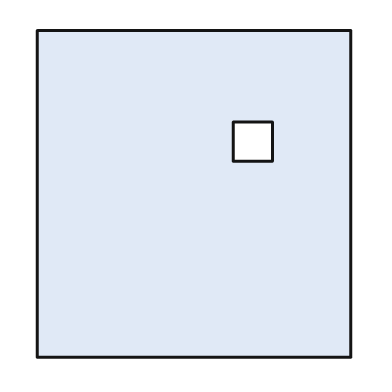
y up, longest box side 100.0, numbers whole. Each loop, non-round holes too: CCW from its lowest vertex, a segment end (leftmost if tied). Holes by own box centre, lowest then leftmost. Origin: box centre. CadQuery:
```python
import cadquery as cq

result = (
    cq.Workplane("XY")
    .moveTo(-48.0, -50.0)
    .lineTo(48.0, -50.0)
    .lineTo(48.0, 50.0)
    .lineTo(-48.0, 50.0)
    .close()
    .moveTo(12.0, 10.0)
    .lineTo(24.0, 10.0)
    .lineTo(24.0, 22.0)
    .lineTo(12.0, 22.0)
    .close()
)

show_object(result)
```